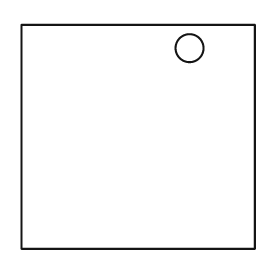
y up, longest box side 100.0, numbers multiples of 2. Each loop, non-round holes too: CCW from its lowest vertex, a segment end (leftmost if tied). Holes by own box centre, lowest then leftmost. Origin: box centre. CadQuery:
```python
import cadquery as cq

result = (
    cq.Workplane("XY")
    .moveTo(-50.0, -48.0)
    .lineTo(50.0, -48.0)
    .lineTo(50.0, 48.0)
    .lineTo(-50.0, 48.0)
    .close()
    .moveTo(22.0, 38.0)
    .circle(6.0)
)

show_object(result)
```